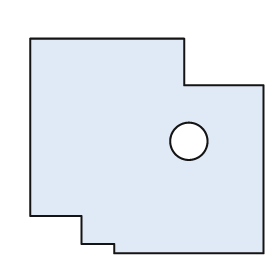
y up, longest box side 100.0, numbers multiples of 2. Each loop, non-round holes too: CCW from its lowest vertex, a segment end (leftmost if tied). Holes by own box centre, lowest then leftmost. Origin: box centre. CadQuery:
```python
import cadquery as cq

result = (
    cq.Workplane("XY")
    .moveTo(-14.0, -46.0)
    .lineTo(50.0, -46.0)
    .lineTo(50.0, 26.0)
    .lineTo(16.0, 26.0)
    .lineTo(16.0, 46.0)
    .lineTo(-50.0, 46.0)
    .lineTo(-50.0, -30.0)
    .lineTo(-28.0, -30.0)
    .lineTo(-28.0, -42.0)
    .lineTo(-14.0, -42.0)
    .close()
    .moveTo(18.0, 2.0)
    .circle(8.0)
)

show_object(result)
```